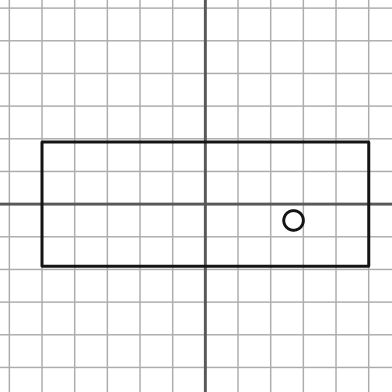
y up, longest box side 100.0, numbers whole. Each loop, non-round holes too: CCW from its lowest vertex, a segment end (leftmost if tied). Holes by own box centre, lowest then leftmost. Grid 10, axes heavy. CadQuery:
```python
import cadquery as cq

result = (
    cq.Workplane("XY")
    .moveTo(-50.0, -19.0)
    .lineTo(50.0, -19.0)
    .lineTo(50.0, 19.0)
    .lineTo(-50.0, 19.0)
    .close()
    .moveTo(27.0, -5.0)
    .circle(3.0)
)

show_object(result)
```